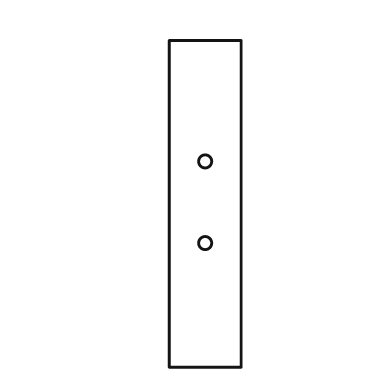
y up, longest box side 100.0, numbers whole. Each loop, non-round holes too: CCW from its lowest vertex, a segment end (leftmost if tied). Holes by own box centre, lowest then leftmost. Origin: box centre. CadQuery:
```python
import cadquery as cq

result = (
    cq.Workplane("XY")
    .moveTo(-11.0, -50.0)
    .lineTo(11.0, -50.0)
    .lineTo(11.0, 50.0)
    .lineTo(-11.0, 50.0)
    .close()
    .moveTo(0.0, -12.0)
    .circle(2.0)
    .moveTo(0.0, 13.0)
    .circle(2.0)
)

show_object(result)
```